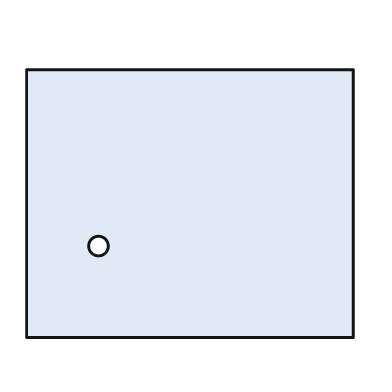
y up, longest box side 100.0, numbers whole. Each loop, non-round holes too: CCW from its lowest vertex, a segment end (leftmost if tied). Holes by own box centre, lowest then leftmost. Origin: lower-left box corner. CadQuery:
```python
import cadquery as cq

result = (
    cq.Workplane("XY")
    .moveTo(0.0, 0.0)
    .lineTo(100.0, 0.0)
    .lineTo(100.0, 82.0)
    .lineTo(0.0, 82.0)
    .close()
    .moveTo(22.0, 28.0)
    .circle(3.0)
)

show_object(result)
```